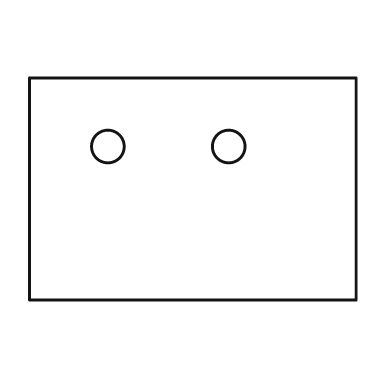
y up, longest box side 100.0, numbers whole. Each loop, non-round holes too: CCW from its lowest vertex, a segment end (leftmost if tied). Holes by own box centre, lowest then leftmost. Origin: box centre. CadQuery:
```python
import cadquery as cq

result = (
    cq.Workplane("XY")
    .moveTo(-50.0, -34.0)
    .lineTo(50.0, -34.0)
    .lineTo(50.0, 34.0)
    .lineTo(-50.0, 34.0)
    .close()
    .moveTo(-26.0, 13.0)
    .circle(5.0)
    .moveTo(11.0, 13.0)
    .circle(5.0)
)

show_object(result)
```